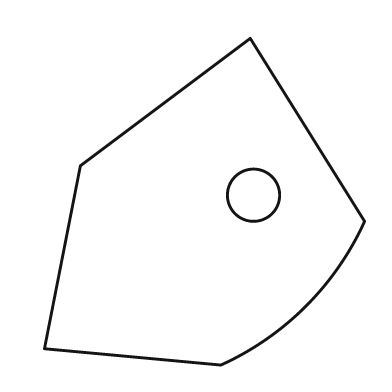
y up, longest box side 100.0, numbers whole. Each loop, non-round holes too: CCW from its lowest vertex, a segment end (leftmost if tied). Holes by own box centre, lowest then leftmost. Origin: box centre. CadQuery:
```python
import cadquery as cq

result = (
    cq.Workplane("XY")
    .moveTo(5.0, -50.0)
    .threePointArc((31.0, -32.0), (49.0, -6.0))
    .lineTo(14.0, 50.0)
    .lineTo(-38.0, 11.0)
    .lineTo(-49.0, -45.0)
    .close()
    .moveTo(15.0, 2.0)
    .circle(8.0)
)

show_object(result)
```